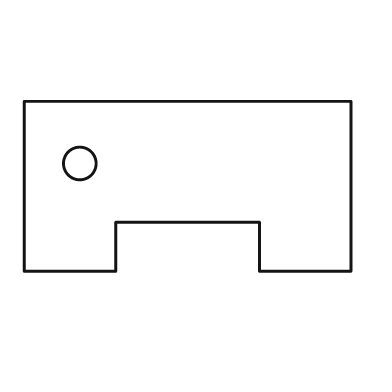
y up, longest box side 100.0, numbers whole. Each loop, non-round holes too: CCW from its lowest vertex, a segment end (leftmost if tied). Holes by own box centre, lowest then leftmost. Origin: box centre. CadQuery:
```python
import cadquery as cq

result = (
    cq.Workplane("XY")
    .moveTo(-50.0, -26.0)
    .lineTo(-22.0, -26.0)
    .lineTo(-22.0, -11.0)
    .lineTo(22.0, -11.0)
    .lineTo(22.0, -26.0)
    .lineTo(50.0, -26.0)
    .lineTo(50.0, 26.0)
    .lineTo(-50.0, 26.0)
    .close()
    .moveTo(-33.0, 7.0)
    .circle(5.0)
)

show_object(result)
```